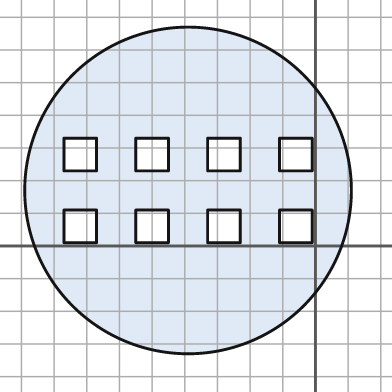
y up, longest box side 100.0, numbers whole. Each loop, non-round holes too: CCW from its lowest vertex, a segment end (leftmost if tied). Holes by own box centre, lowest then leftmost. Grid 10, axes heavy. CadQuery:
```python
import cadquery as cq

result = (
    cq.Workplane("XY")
    .moveTo(-39.0, 17.0)
    .circle(50.0)
    .moveTo(-77.0, 1.0)
    .lineTo(-67.0, 1.0)
    .lineTo(-67.0, 11.0)
    .lineTo(-77.0, 11.0)
    .close()
    .moveTo(-55.0, 1.0)
    .lineTo(-45.0, 1.0)
    .lineTo(-45.0, 11.0)
    .lineTo(-55.0, 11.0)
    .close()
    .moveTo(-33.0, 1.0)
    .lineTo(-23.0, 1.0)
    .lineTo(-23.0, 11.0)
    .lineTo(-33.0, 11.0)
    .close()
    .moveTo(-11.0, 1.0)
    .lineTo(-1.0, 1.0)
    .lineTo(-1.0, 11.0)
    .lineTo(-11.0, 11.0)
    .close()
    .moveTo(-77.0, 23.0)
    .lineTo(-67.0, 23.0)
    .lineTo(-67.0, 33.0)
    .lineTo(-77.0, 33.0)
    .close()
    .moveTo(-55.0, 23.0)
    .lineTo(-45.0, 23.0)
    .lineTo(-45.0, 33.0)
    .lineTo(-55.0, 33.0)
    .close()
    .moveTo(-33.0, 23.0)
    .lineTo(-23.0, 23.0)
    .lineTo(-23.0, 33.0)
    .lineTo(-33.0, 33.0)
    .close()
    .moveTo(-11.0, 23.0)
    .lineTo(-1.0, 23.0)
    .lineTo(-1.0, 33.0)
    .lineTo(-11.0, 33.0)
    .close()
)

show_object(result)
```